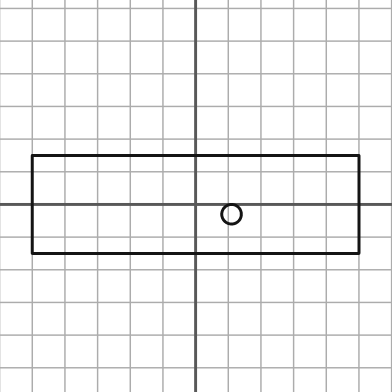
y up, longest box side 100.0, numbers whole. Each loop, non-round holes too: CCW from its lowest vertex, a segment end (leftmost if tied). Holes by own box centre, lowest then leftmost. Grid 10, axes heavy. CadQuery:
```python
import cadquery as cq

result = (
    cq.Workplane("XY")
    .moveTo(-50.0, -15.0)
    .lineTo(50.0, -15.0)
    .lineTo(50.0, 15.0)
    .lineTo(-50.0, 15.0)
    .close()
    .moveTo(11.0, -3.0)
    .circle(3.0)
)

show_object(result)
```